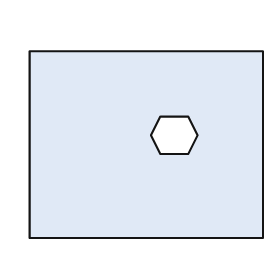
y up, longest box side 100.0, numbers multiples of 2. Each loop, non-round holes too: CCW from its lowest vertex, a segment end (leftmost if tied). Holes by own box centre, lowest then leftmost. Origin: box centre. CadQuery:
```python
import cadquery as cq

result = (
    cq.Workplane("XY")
    .moveTo(-50.0, -40.0)
    .lineTo(50.0, -40.0)
    .lineTo(50.0, 40.0)
    .lineTo(-50.0, 40.0)
    .close()
    .moveTo(6.0, -4.0)
    .lineTo(18.0, -4.0)
    .lineTo(22.0, 4.0)
    .lineTo(18.0, 12.0)
    .lineTo(6.0, 12.0)
    .lineTo(2.0, 4.0)
    .close()
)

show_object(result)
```